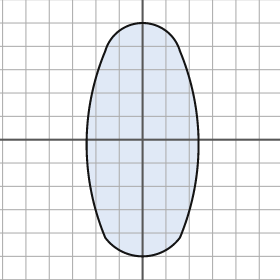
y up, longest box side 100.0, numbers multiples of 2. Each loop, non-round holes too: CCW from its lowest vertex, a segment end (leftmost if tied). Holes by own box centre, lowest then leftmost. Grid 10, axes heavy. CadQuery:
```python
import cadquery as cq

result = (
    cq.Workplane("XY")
    .moveTo(-16.0, -42.0)
    .threePointArc((0.0, -50.0), (16.0, -42.0))
    .threePointArc((24.0, -2.0), (16.0, 38.0))
    .threePointArc((0.0, 50.0), (-16.0, 38.0))
    .threePointArc((-24.0, -2.0), (-16.0, -42.0))
    .close()
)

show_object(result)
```